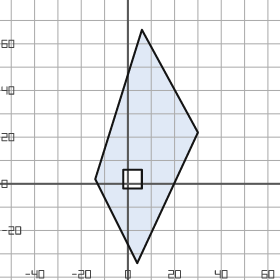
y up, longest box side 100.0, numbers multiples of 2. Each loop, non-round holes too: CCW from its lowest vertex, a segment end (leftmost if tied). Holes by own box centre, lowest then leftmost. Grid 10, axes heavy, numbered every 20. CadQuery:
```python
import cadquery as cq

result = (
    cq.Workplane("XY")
    .moveTo(4.0, -34.0)
    .lineTo(30.0, 22.0)
    .lineTo(6.0, 66.0)
    .lineTo(-14.0, 2.0)
    .close()
    .moveTo(-2.0, -2.0)
    .lineTo(6.0, -2.0)
    .lineTo(6.0, 6.0)
    .lineTo(-2.0, 6.0)
    .close()
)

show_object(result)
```